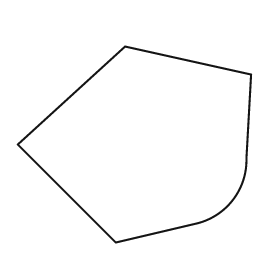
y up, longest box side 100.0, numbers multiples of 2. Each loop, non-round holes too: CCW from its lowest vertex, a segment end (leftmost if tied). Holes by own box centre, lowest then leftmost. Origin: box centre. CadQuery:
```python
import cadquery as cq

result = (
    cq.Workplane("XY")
    .moveTo(-8.0, -42.0)
    .lineTo(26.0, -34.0)
    .threePointArc((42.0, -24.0), (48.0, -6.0))
    .lineTo(50.0, 30.0)
    .lineTo(-4.0, 42.0)
    .lineTo(-50.0, 0.0)
    .close()
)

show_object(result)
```